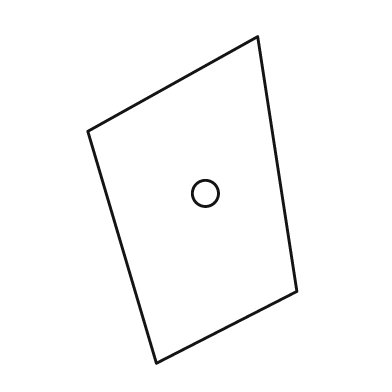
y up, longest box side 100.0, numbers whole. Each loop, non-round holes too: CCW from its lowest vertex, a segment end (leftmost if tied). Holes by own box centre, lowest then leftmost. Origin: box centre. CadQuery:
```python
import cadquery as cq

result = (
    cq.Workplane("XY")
    .moveTo(-11.0, -50.0)
    .lineTo(32.0, -28.0)
    .lineTo(20.0, 50.0)
    .lineTo(-32.0, 21.0)
    .close()
    .moveTo(4.0, 2.0)
    .circle(4.0)
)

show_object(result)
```